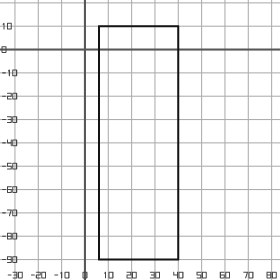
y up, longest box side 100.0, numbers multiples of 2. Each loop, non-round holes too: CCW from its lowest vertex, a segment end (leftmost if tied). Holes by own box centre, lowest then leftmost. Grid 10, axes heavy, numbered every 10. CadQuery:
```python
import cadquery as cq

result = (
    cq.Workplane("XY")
    .moveTo(6.0, -90.0)
    .lineTo(40.0, -90.0)
    .lineTo(40.0, 10.0)
    .lineTo(6.0, 10.0)
    .close()
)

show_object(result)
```